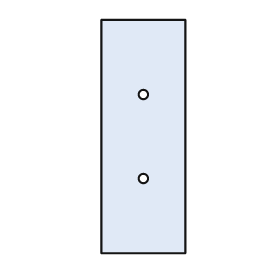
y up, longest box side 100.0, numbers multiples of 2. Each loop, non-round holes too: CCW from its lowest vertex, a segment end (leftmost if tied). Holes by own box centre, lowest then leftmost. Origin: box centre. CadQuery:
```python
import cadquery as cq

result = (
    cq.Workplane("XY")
    .moveTo(-18.0, -50.0)
    .lineTo(18.0, -50.0)
    .lineTo(18.0, 50.0)
    .lineTo(-18.0, 50.0)
    .close()
    .moveTo(0.0, -18.0)
    .circle(2.0)
    .moveTo(0.0, 18.0)
    .circle(2.0)
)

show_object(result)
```